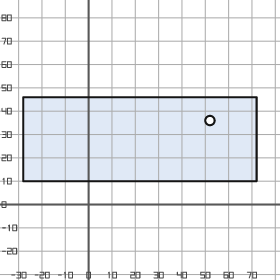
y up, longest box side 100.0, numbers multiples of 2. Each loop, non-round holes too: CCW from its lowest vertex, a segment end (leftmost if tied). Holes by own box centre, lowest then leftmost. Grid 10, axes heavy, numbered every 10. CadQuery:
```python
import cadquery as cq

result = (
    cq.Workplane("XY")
    .moveTo(-28.0, 10.0)
    .lineTo(72.0, 10.0)
    .lineTo(72.0, 46.0)
    .lineTo(-28.0, 46.0)
    .close()
    .moveTo(52.0, 36.0)
    .circle(2.0)
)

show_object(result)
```